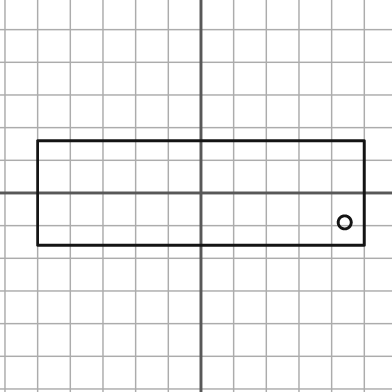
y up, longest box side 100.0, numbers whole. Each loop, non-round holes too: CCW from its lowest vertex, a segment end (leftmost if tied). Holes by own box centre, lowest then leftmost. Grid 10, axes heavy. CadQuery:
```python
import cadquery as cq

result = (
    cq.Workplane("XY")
    .moveTo(-50.0, -16.0)
    .lineTo(50.0, -16.0)
    .lineTo(50.0, 16.0)
    .lineTo(-50.0, 16.0)
    .close()
    .moveTo(44.0, -9.0)
    .circle(2.0)
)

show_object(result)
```